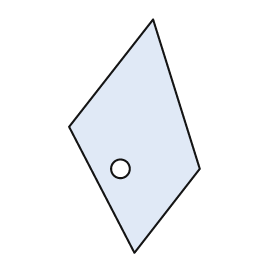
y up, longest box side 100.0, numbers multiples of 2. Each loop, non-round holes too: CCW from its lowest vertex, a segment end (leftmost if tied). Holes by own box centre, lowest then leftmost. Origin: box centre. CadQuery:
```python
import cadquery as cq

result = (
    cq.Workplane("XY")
    .moveTo(0.0, -50.0)
    .lineTo(28.0, -14.0)
    .lineTo(8.0, 50.0)
    .lineTo(-28.0, 4.0)
    .close()
    .moveTo(-6.0, -14.0)
    .circle(4.0)
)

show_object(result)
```